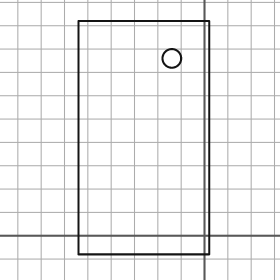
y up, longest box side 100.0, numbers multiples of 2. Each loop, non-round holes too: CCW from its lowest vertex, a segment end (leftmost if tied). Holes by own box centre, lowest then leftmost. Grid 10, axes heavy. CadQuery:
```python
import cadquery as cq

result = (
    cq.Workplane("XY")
    .moveTo(-54.0, -8.0)
    .lineTo(2.0, -8.0)
    .lineTo(2.0, 92.0)
    .lineTo(-54.0, 92.0)
    .close()
    .moveTo(-14.0, 76.0)
    .circle(4.0)
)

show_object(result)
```